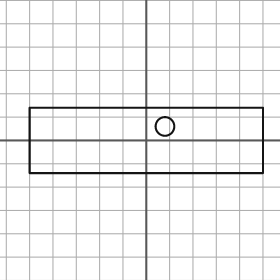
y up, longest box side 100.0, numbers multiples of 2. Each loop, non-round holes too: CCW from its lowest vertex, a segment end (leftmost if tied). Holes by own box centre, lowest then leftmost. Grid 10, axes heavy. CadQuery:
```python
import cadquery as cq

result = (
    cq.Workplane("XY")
    .moveTo(-50.0, -14.0)
    .lineTo(50.0, -14.0)
    .lineTo(50.0, 14.0)
    .lineTo(-50.0, 14.0)
    .close()
    .moveTo(8.0, 6.0)
    .circle(4.0)
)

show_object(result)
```